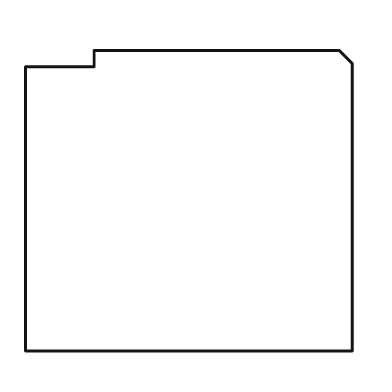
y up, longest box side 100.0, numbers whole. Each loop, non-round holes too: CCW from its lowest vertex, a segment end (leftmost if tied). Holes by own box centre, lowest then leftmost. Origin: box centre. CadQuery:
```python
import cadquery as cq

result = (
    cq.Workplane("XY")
    .moveTo(-50.0, -46.0)
    .lineTo(50.0, -46.0)
    .lineTo(50.0, 42.0)
    .lineTo(46.0, 46.0)
    .lineTo(-29.0, 46.0)
    .lineTo(-29.0, 41.0)
    .lineTo(-50.0, 41.0)
    .close()
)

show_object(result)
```